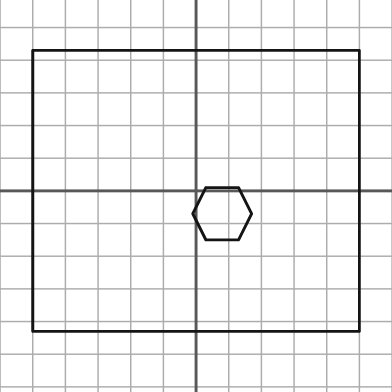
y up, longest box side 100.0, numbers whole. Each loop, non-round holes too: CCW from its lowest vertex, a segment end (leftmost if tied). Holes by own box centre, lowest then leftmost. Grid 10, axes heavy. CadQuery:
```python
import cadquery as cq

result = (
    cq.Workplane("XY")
    .moveTo(-50.0, -43.0)
    .lineTo(50.0, -43.0)
    .lineTo(50.0, 43.0)
    .lineTo(-50.0, 43.0)
    .close()
    .moveTo(3.0, -15.0)
    .lineTo(13.0, -15.0)
    .lineTo(17.0, -7.0)
    .lineTo(13.0, 1.0)
    .lineTo(3.0, 1.0)
    .lineTo(-1.0, -7.0)
    .close()
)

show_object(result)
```